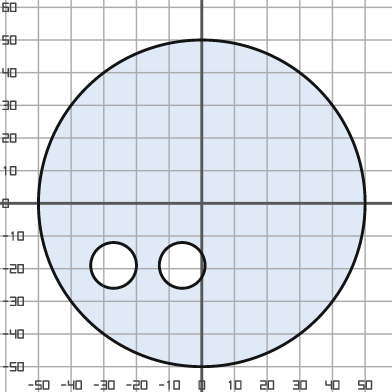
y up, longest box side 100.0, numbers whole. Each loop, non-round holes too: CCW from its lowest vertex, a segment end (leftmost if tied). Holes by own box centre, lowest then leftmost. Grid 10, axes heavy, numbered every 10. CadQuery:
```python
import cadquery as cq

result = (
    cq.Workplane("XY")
    .moveTo(0.0, 0.0)
    .circle(50.0)
    .moveTo(-27.0, -19.0)
    .circle(7.0)
    .moveTo(-6.0, -19.0)
    .circle(7.0)
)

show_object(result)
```